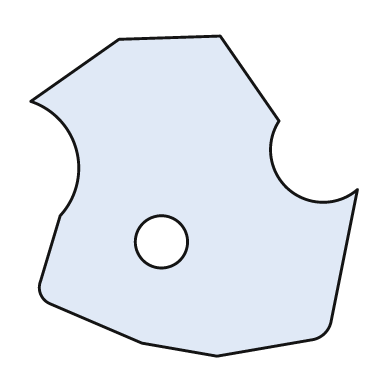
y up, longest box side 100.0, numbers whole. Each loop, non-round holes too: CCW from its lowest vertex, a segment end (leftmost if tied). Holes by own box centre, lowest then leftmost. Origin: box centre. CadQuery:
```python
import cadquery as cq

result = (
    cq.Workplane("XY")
    .moveTo(7.0, -49.0)
    .lineTo(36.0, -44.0)
    .threePointArc((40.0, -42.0), (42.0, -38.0))
    .lineTo(50.0, 2.0)
    .threePointArc((29.0, 2.0), (26.0, 23.0))
    .lineTo(8.0, 49.0)
    .lineTo(-23.0, 48.0)
    .lineTo(-50.0, 29.0)
    .threePointArc((-36.0, 14.0), (-41.0, -6.0))
    .lineTo(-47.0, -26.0)
    .threePointArc((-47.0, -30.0), (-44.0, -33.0))
    .lineTo(-16.0, -45.0)
    .close()
    .moveTo(-10.0, -14.0)
    .circle(8.0)
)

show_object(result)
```